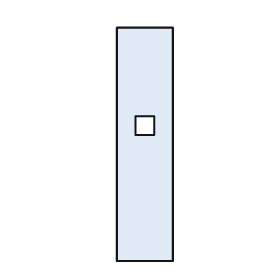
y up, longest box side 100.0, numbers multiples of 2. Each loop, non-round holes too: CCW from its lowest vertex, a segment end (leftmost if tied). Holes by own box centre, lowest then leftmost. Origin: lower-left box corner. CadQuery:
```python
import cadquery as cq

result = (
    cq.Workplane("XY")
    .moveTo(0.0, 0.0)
    .lineTo(24.0, 0.0)
    .lineTo(24.0, 100.0)
    .lineTo(0.0, 100.0)
    .close()
    .moveTo(8.0, 54.0)
    .lineTo(16.0, 54.0)
    .lineTo(16.0, 62.0)
    .lineTo(8.0, 62.0)
    .close()
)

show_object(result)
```